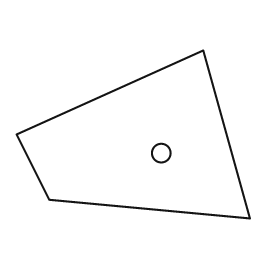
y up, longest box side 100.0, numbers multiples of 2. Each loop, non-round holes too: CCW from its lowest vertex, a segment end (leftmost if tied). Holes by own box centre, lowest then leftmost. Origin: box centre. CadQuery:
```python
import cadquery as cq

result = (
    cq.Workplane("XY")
    .moveTo(50.0, -36.0)
    .lineTo(30.0, 36.0)
    .lineTo(-50.0, 0.0)
    .lineTo(-36.0, -28.0)
    .close()
    .moveTo(12.0, -8.0)
    .circle(4.0)
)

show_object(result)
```